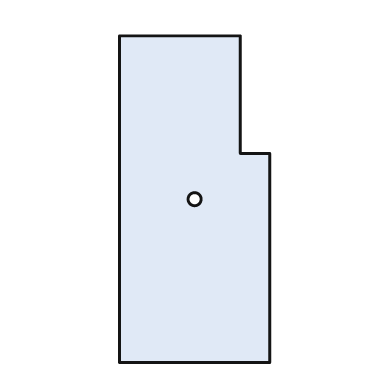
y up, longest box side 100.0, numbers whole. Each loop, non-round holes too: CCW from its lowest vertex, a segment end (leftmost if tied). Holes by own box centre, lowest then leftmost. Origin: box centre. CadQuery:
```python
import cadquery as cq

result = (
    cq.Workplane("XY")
    .moveTo(-23.0, -50.0)
    .lineTo(23.0, -50.0)
    .lineTo(23.0, 14.0)
    .lineTo(14.0, 14.0)
    .lineTo(14.0, 50.0)
    .lineTo(-23.0, 50.0)
    .close()
    .moveTo(0.0, 0.0)
    .circle(2.0)
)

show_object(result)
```